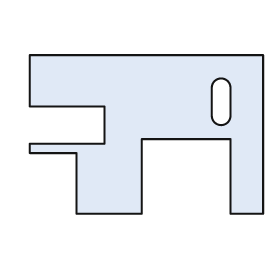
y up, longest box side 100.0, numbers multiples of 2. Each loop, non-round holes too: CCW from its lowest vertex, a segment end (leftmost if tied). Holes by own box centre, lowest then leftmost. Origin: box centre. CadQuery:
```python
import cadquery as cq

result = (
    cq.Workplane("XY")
    .moveTo(-30.0, -34.0)
    .lineTo(-2.0, -34.0)
    .lineTo(-2.0, -2.0)
    .lineTo(36.0, -2.0)
    .lineTo(36.0, -34.0)
    .lineTo(50.0, -34.0)
    .lineTo(50.0, 34.0)
    .lineTo(-50.0, 34.0)
    .lineTo(-50.0, 12.0)
    .lineTo(-18.0, 12.0)
    .lineTo(-18.0, -4.0)
    .lineTo(-50.0, -4.0)
    .lineTo(-50.0, -8.0)
    .lineTo(-30.0, -8.0)
    .close()
    .moveTo(28.0, 8.0)
    .threePointArc((32.0, 4.0), (36.0, 8.0))
    .lineTo(36.0, 20.0)
    .threePointArc((32.0, 24.0), (28.0, 20.0))
    .close()
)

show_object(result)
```